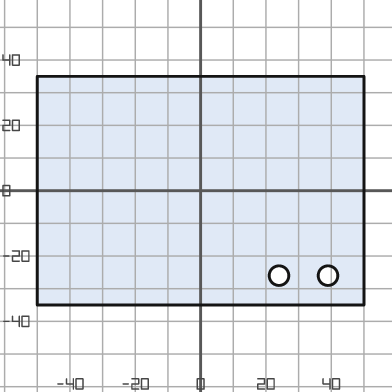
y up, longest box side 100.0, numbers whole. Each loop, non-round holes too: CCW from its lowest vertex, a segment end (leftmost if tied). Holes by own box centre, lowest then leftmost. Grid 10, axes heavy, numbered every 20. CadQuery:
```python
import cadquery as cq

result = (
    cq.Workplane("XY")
    .moveTo(-50.0, -35.0)
    .lineTo(50.0, -35.0)
    .lineTo(50.0, 35.0)
    .lineTo(-50.0, 35.0)
    .close()
    .moveTo(24.0, -26.0)
    .circle(3.0)
    .moveTo(39.0, -26.0)
    .circle(3.0)
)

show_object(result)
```